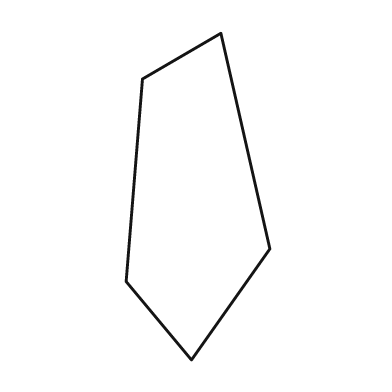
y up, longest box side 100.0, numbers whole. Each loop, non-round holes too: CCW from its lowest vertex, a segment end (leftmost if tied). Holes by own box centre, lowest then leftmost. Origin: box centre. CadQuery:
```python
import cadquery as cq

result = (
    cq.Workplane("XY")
    .moveTo(-2.0, -50.0)
    .lineTo(22.0, -16.0)
    .lineTo(7.0, 50.0)
    .lineTo(-17.0, 36.0)
    .lineTo(-22.0, -26.0)
    .close()
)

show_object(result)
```